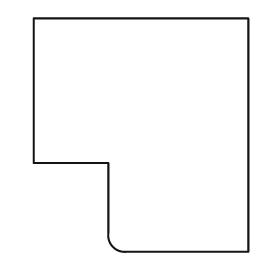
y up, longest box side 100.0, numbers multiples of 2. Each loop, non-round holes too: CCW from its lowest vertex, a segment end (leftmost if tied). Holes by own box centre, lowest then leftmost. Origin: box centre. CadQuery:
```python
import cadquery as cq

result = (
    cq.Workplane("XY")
    .moveTo(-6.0, -50.0)
    .lineTo(46.0, -50.0)
    .lineTo(46.0, 50.0)
    .lineTo(-46.0, 50.0)
    .lineTo(-46.0, -12.0)
    .lineTo(-14.0, -12.0)
    .lineTo(-14.0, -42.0)
    .threePointArc((-12.0, -48.0), (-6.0, -50.0))
    .close()
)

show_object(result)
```